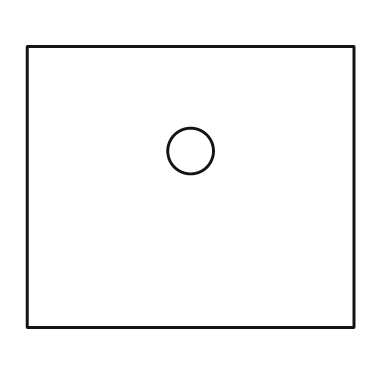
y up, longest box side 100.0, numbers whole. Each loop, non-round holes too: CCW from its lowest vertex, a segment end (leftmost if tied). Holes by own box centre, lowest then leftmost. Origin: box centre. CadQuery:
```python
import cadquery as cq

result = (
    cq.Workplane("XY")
    .moveTo(-50.0, -43.0)
    .lineTo(50.0, -43.0)
    .lineTo(50.0, 43.0)
    .lineTo(-50.0, 43.0)
    .close()
    .moveTo(0.0, 11.0)
    .circle(7.0)
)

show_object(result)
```